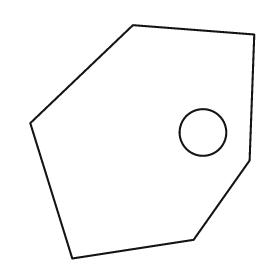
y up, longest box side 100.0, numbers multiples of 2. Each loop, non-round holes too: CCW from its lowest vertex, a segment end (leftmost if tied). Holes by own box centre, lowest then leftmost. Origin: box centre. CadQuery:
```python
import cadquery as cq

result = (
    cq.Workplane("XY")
    .moveTo(-30.0, -50.0)
    .lineTo(22.0, -42.0)
    .lineTo(46.0, -8.0)
    .lineTo(48.0, 46.0)
    .lineTo(-4.0, 50.0)
    .lineTo(-48.0, 8.0)
    .close()
    .moveTo(26.0, 4.0)
    .circle(10.0)
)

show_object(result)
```